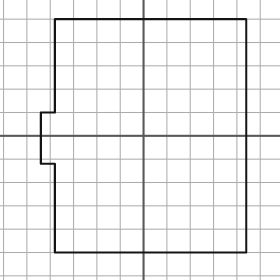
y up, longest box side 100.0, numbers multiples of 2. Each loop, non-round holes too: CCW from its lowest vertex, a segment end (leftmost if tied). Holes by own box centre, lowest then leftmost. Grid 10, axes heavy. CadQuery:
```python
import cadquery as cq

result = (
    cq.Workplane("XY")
    .moveTo(-38.0, -50.0)
    .lineTo(44.0, -50.0)
    .lineTo(44.0, 50.0)
    .lineTo(-38.0, 50.0)
    .lineTo(-38.0, 10.0)
    .lineTo(-44.0, 10.0)
    .lineTo(-44.0, -12.0)
    .lineTo(-38.0, -12.0)
    .close()
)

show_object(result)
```